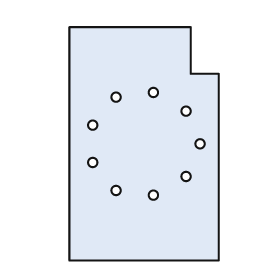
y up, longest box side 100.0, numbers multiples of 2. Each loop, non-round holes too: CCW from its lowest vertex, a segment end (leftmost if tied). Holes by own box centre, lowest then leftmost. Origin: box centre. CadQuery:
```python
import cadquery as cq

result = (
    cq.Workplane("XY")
    .moveTo(-32.0, -50.0)
    .lineTo(32.0, -50.0)
    .lineTo(32.0, 30.0)
    .lineTo(20.0, 30.0)
    .lineTo(20.0, 50.0)
    .lineTo(-32.0, 50.0)
    .close()
    .moveTo(4.0, -22.0)
    .circle(2.0)
    .moveTo(-12.0, -20.0)
    .circle(2.0)
    .moveTo(18.0, -14.0)
    .circle(2.0)
    .moveTo(-22.0, -8.0)
    .circle(2.0)
    .moveTo(24.0, 0.0)
    .circle(2.0)
    .moveTo(-22.0, 8.0)
    .circle(2.0)
    .moveTo(18.0, 14.0)
    .circle(2.0)
    .moveTo(-12.0, 20.0)
    .circle(2.0)
    .moveTo(4.0, 22.0)
    .circle(2.0)
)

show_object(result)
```